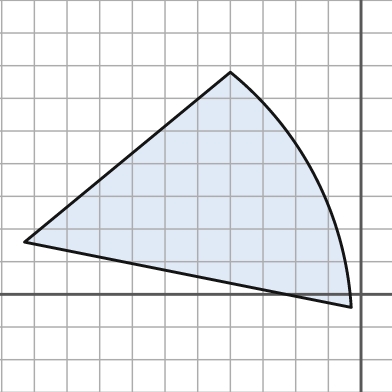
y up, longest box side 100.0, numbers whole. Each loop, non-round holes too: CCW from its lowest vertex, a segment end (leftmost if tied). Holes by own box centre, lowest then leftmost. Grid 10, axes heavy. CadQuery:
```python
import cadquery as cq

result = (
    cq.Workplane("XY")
    .moveTo(-3.0, -4.0)
    .threePointArc((-14.0, 36.0), (-40.0, 68.0))
    .lineTo(-103.0, 16.0)
    .close()
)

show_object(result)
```